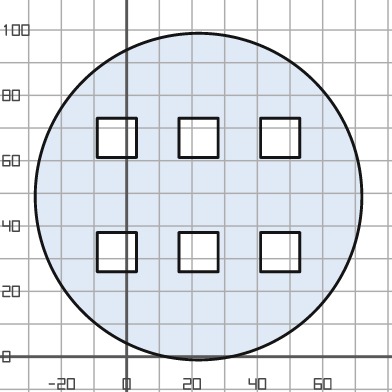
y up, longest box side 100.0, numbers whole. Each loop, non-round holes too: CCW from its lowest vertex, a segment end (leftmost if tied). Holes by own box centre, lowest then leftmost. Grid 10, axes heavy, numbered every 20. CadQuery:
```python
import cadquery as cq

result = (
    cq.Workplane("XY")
    .moveTo(22.0, 49.0)
    .circle(50.0)
    .moveTo(-9.0, 26.0)
    .lineTo(3.0, 26.0)
    .lineTo(3.0, 38.0)
    .lineTo(-9.0, 38.0)
    .close()
    .moveTo(16.0, 26.0)
    .lineTo(28.0, 26.0)
    .lineTo(28.0, 38.0)
    .lineTo(16.0, 38.0)
    .close()
    .moveTo(41.0, 26.0)
    .lineTo(53.0, 26.0)
    .lineTo(53.0, 38.0)
    .lineTo(41.0, 38.0)
    .close()
    .moveTo(-9.0, 61.0)
    .lineTo(3.0, 61.0)
    .lineTo(3.0, 73.0)
    .lineTo(-9.0, 73.0)
    .close()
    .moveTo(16.0, 61.0)
    .lineTo(28.0, 61.0)
    .lineTo(28.0, 73.0)
    .lineTo(16.0, 73.0)
    .close()
    .moveTo(41.0, 61.0)
    .lineTo(53.0, 61.0)
    .lineTo(53.0, 73.0)
    .lineTo(41.0, 73.0)
    .close()
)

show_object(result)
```